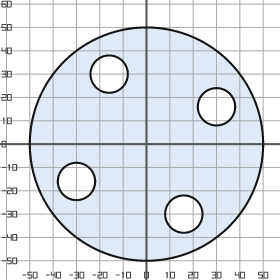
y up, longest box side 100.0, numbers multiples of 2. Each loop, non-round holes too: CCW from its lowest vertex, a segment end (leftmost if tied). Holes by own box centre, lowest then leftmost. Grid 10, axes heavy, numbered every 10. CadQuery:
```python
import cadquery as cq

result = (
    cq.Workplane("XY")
    .moveTo(0.0, 0.0)
    .circle(50.0)
    .moveTo(16.0, -30.0)
    .circle(8.0)
    .moveTo(-30.0, -16.0)
    .circle(8.0)
    .moveTo(30.0, 16.0)
    .circle(8.0)
    .moveTo(-16.0, 30.0)
    .circle(8.0)
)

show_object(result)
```